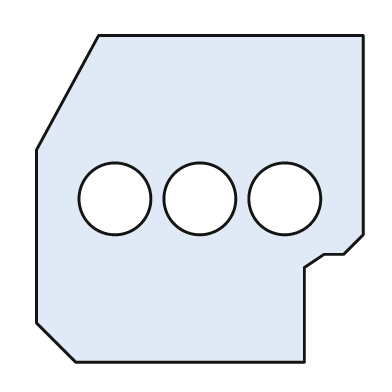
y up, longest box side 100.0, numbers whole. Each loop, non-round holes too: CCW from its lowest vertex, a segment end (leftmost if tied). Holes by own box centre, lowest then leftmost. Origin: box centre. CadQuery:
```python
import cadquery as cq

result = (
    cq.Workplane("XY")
    .moveTo(-38.0, -50.0)
    .lineTo(32.0, -50.0)
    .lineTo(32.0, -21.0)
    .lineTo(38.0, -17.0)
    .lineTo(44.0, -17.0)
    .lineTo(50.0, -11.0)
    .lineTo(50.0, 50.0)
    .lineTo(-31.0, 50.0)
    .lineTo(-50.0, 15.0)
    .lineTo(-50.0, -38.0)
    .close()
    .moveTo(-26.0, 0.0)
    .circle(11.0)
    .moveTo(0.0, 0.0)
    .circle(11.0)
    .moveTo(26.0, 0.0)
    .circle(11.0)
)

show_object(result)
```